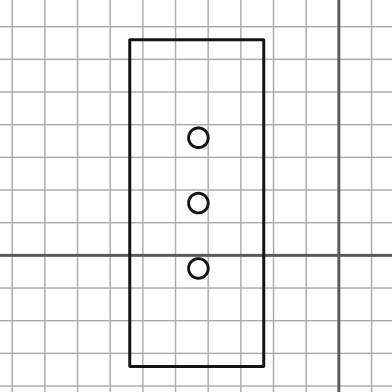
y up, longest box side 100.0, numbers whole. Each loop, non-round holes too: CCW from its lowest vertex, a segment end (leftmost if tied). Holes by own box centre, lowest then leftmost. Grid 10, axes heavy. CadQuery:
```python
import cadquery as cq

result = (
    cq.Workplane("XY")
    .moveTo(-64.0, -34.0)
    .lineTo(-23.0, -34.0)
    .lineTo(-23.0, 66.0)
    .lineTo(-64.0, 66.0)
    .close()
    .moveTo(-43.0, -4.0)
    .circle(3.0)
    .moveTo(-43.0, 16.0)
    .circle(3.0)
    .moveTo(-43.0, 36.0)
    .circle(3.0)
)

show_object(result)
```